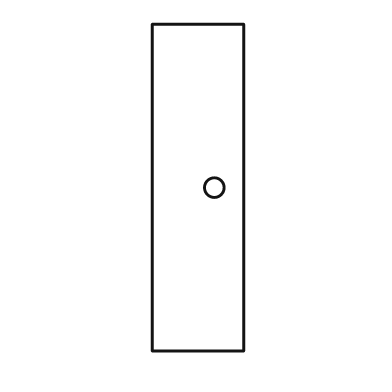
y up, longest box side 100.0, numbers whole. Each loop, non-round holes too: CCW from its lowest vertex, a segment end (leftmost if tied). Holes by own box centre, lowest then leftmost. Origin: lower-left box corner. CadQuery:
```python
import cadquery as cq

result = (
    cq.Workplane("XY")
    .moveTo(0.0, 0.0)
    .lineTo(28.0, 0.0)
    .lineTo(28.0, 100.0)
    .lineTo(0.0, 100.0)
    .close()
    .moveTo(19.0, 50.0)
    .circle(3.0)
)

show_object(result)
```